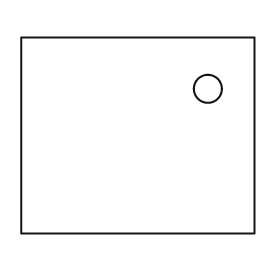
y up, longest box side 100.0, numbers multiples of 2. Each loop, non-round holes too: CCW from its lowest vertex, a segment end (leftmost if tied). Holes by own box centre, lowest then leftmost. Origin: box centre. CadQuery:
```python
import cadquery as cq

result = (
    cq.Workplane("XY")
    .moveTo(-50.0, -42.0)
    .lineTo(50.0, -42.0)
    .lineTo(50.0, 42.0)
    .lineTo(-50.0, 42.0)
    .close()
    .moveTo(30.0, 20.0)
    .circle(6.0)
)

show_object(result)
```